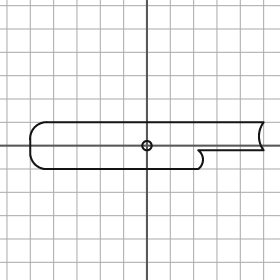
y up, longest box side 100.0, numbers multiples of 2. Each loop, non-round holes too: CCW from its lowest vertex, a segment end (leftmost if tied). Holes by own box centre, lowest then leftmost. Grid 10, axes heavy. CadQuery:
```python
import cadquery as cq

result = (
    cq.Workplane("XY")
    .moveTo(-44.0, -10.0)
    .lineTo(22.0, -10.0)
    .threePointArc((24.0, -6.0), (22.0, -2.0))
    .lineTo(50.0, -2.0)
    .threePointArc((48.0, 4.0), (50.0, 10.0))
    .lineTo(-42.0, 10.0)
    .threePointArc((-48.0, 8.0), (-50.0, 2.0))
    .lineTo(-50.0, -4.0)
    .threePointArc((-48.0, -8.0), (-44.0, -10.0))
    .close()
    .moveTo(0.0, 0.0)
    .circle(2.0)
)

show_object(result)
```